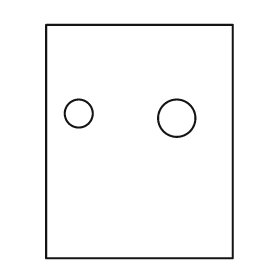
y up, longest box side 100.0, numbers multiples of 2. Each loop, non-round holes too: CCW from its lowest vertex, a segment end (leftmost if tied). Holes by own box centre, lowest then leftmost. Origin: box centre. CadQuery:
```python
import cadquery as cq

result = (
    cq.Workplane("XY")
    .moveTo(-40.0, -50.0)
    .lineTo(40.0, -50.0)
    .lineTo(40.0, 50.0)
    .lineTo(-40.0, 50.0)
    .close()
    .moveTo(16.0, 10.0)
    .circle(8.0)
    .moveTo(-26.0, 12.0)
    .circle(6.0)
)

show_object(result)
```